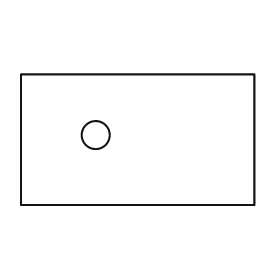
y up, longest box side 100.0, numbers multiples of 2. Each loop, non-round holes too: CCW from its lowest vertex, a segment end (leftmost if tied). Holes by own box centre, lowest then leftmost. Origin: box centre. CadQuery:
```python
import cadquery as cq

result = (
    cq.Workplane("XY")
    .moveTo(-50.0, -28.0)
    .lineTo(50.0, -28.0)
    .lineTo(50.0, 28.0)
    .lineTo(-50.0, 28.0)
    .close()
    .moveTo(-18.0, 2.0)
    .circle(6.0)
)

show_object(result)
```